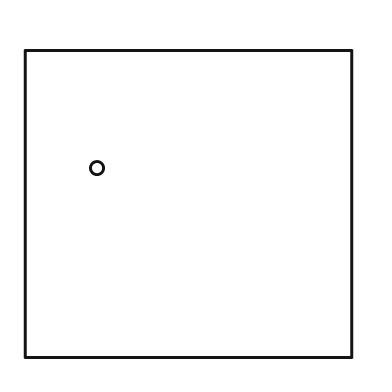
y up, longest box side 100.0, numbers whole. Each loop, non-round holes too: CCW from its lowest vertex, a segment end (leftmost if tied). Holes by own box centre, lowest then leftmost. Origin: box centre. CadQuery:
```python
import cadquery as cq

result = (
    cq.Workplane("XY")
    .moveTo(-50.0, -47.0)
    .lineTo(50.0, -47.0)
    .lineTo(50.0, 47.0)
    .lineTo(-50.0, 47.0)
    .close()
    .moveTo(-28.0, 11.0)
    .circle(2.0)
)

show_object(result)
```